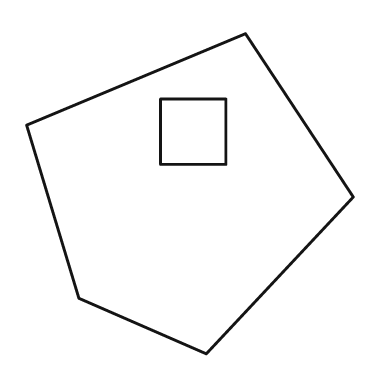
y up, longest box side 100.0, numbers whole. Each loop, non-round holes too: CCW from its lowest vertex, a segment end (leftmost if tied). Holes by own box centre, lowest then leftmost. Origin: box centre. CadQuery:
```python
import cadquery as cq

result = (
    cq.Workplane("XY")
    .moveTo(5.0, -49.0)
    .lineTo(50.0, -1.0)
    .lineTo(17.0, 49.0)
    .lineTo(-50.0, 21.0)
    .lineTo(-34.0, -32.0)
    .close()
    .moveTo(-9.0, 9.0)
    .lineTo(11.0, 9.0)
    .lineTo(11.0, 29.0)
    .lineTo(-9.0, 29.0)
    .close()
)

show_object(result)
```